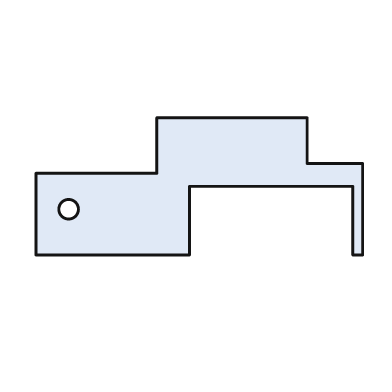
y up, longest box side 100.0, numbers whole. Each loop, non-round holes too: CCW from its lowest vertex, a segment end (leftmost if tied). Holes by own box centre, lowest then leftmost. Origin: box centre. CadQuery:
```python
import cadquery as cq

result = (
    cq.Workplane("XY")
    .moveTo(-50.0, -21.0)
    .lineTo(-3.0, -21.0)
    .lineTo(-3.0, 0.0)
    .lineTo(47.0, 0.0)
    .lineTo(47.0, -21.0)
    .lineTo(50.0, -21.0)
    .lineTo(50.0, 7.0)
    .lineTo(33.0, 7.0)
    .lineTo(33.0, 21.0)
    .lineTo(-13.0, 21.0)
    .lineTo(-13.0, 4.0)
    .lineTo(-50.0, 4.0)
    .close()
    .moveTo(-40.0, -7.0)
    .circle(3.0)
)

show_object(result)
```